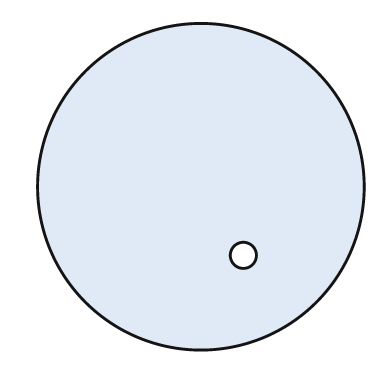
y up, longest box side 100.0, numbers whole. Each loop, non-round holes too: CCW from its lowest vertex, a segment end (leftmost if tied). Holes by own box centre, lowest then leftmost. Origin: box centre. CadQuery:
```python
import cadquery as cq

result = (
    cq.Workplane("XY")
    .moveTo(0.0, 0.0)
    .circle(50.0)
    .moveTo(13.0, -21.0)
    .circle(4.0)
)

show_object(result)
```